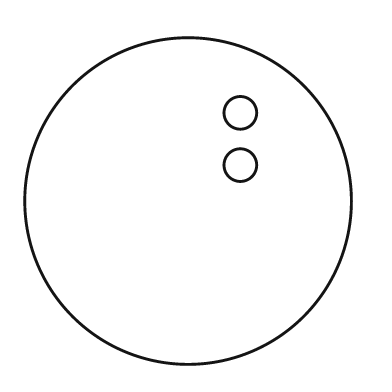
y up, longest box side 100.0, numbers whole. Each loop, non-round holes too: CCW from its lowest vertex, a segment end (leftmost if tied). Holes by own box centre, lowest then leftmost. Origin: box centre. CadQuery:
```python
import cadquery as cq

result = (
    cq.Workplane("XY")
    .moveTo(0.0, 0.0)
    .circle(50.0)
    .moveTo(16.0, 11.0)
    .circle(5.0)
    .moveTo(16.0, 27.0)
    .circle(5.0)
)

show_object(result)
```